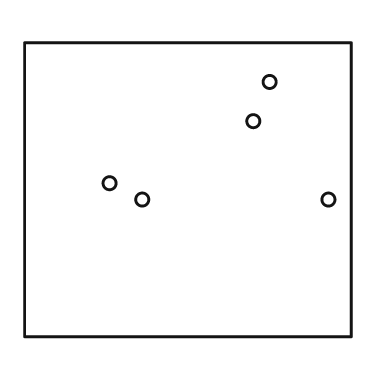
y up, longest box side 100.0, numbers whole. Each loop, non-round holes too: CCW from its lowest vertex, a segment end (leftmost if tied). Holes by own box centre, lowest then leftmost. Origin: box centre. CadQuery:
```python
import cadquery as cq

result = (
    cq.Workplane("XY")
    .moveTo(-50.0, -45.0)
    .lineTo(50.0, -45.0)
    .lineTo(50.0, 45.0)
    .lineTo(-50.0, 45.0)
    .close()
    .moveTo(-14.0, -3.0)
    .circle(2.0)
    .moveTo(43.0, -3.0)
    .circle(2.0)
    .moveTo(-24.0, 2.0)
    .circle(2.0)
    .moveTo(20.0, 21.0)
    .circle(2.0)
    .moveTo(25.0, 33.0)
    .circle(2.0)
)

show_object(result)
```